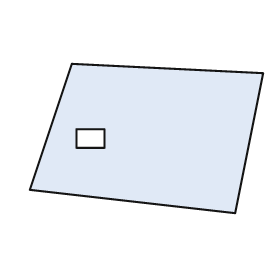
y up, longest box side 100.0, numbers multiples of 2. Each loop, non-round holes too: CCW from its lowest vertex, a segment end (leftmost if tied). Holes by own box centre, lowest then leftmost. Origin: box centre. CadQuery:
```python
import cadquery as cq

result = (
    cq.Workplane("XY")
    .moveTo(38.0, -32.0)
    .lineTo(50.0, 28.0)
    .lineTo(-32.0, 32.0)
    .lineTo(-50.0, -22.0)
    .close()
    .moveTo(-30.0, -4.0)
    .lineTo(-18.0, -4.0)
    .lineTo(-18.0, 4.0)
    .lineTo(-30.0, 4.0)
    .close()
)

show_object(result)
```